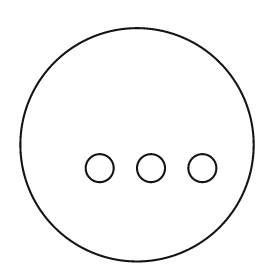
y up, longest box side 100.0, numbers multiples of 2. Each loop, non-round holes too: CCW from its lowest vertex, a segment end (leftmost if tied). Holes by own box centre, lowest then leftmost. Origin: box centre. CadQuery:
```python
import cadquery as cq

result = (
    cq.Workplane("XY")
    .moveTo(0.0, 0.0)
    .circle(50.0)
    .moveTo(-16.0, -10.0)
    .circle(6.0)
    .moveTo(6.0, -10.0)
    .circle(6.0)
    .moveTo(28.0, -10.0)
    .circle(6.0)
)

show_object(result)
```